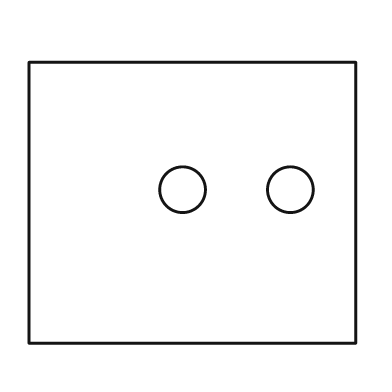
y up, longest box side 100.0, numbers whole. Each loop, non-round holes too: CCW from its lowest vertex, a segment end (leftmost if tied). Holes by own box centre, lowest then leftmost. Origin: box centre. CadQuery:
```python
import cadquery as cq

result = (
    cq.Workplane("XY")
    .moveTo(-50.0, -43.0)
    .lineTo(50.0, -43.0)
    .lineTo(50.0, 43.0)
    .lineTo(-50.0, 43.0)
    .close()
    .moveTo(-3.0, 4.0)
    .circle(7.0)
    .moveTo(30.0, 4.0)
    .circle(7.0)
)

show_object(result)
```